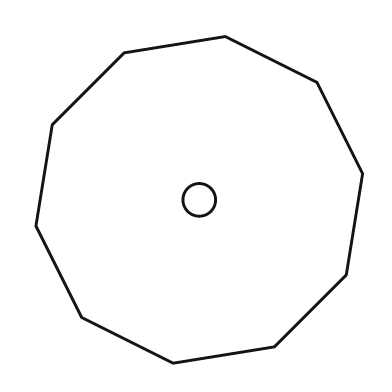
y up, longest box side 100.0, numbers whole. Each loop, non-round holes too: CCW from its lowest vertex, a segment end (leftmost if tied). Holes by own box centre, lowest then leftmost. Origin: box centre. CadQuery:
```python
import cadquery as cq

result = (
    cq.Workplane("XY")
    .moveTo(-8.0, -50.0)
    .lineTo(23.0, -45.0)
    .lineTo(45.0, -23.0)
    .lineTo(50.0, 8.0)
    .lineTo(36.0, 36.0)
    .lineTo(8.0, 50.0)
    .lineTo(-23.0, 45.0)
    .lineTo(-45.0, 23.0)
    .lineTo(-50.0, -8.0)
    .lineTo(-36.0, -36.0)
    .close()
    .moveTo(0.0, 0.0)
    .circle(5.0)
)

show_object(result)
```